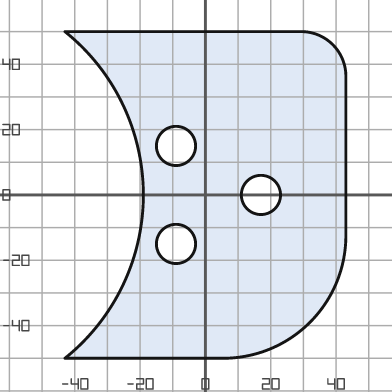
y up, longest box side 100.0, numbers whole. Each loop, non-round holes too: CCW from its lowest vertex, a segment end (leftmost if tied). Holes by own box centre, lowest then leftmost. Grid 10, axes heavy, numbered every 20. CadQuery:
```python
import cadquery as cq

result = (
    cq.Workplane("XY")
    .moveTo(-43.0, -50.0)
    .lineTo(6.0, -50.0)
    .threePointArc((32.0, -39.0), (43.0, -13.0))
    .lineTo(43.0, 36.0)
    .threePointArc((39.0, 46.0), (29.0, 50.0))
    .lineTo(-43.0, 50.0)
    .threePointArc((-19.0, 0.0), (-43.0, -50.0))
    .close()
    .moveTo(-9.0, -15.0)
    .circle(6.0)
    .moveTo(17.0, 0.0)
    .circle(6.0)
    .moveTo(-9.0, 15.0)
    .circle(6.0)
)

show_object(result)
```